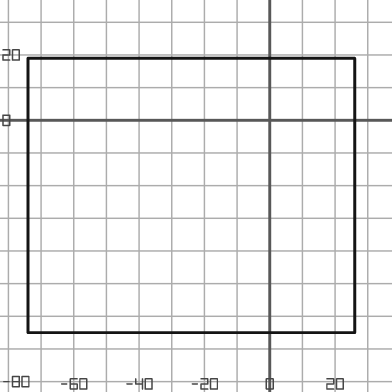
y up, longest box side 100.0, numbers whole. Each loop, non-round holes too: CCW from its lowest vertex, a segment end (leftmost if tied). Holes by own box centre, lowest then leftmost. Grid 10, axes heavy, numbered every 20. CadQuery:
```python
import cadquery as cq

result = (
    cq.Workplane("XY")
    .moveTo(-74.0, -65.0)
    .lineTo(26.0, -65.0)
    .lineTo(26.0, 19.0)
    .lineTo(-74.0, 19.0)
    .close()
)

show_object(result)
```